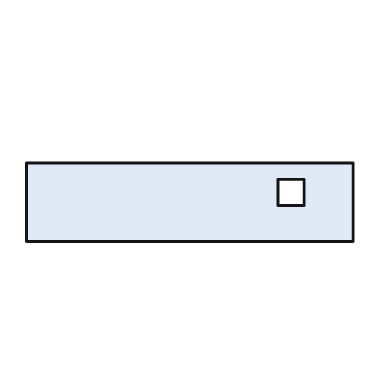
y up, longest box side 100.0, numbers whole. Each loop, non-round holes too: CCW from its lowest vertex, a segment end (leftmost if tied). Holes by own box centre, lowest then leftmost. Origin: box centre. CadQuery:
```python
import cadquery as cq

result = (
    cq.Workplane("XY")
    .moveTo(-50.0, -12.0)
    .lineTo(50.0, -12.0)
    .lineTo(50.0, 12.0)
    .lineTo(-50.0, 12.0)
    .close()
    .moveTo(27.0, -1.0)
    .lineTo(35.0, -1.0)
    .lineTo(35.0, 7.0)
    .lineTo(27.0, 7.0)
    .close()
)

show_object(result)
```